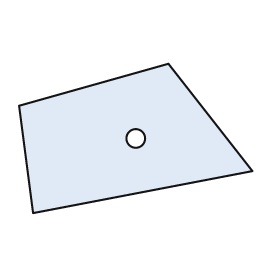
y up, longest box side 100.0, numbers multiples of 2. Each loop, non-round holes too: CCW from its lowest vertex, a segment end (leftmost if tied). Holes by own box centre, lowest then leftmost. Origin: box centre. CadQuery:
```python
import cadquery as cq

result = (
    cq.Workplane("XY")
    .moveTo(-44.0, -32.0)
    .lineTo(50.0, -14.0)
    .lineTo(14.0, 32.0)
    .lineTo(-50.0, 14.0)
    .close()
    .moveTo(0.0, 0.0)
    .circle(4.0)
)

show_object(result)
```